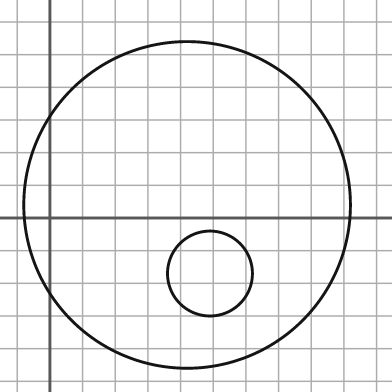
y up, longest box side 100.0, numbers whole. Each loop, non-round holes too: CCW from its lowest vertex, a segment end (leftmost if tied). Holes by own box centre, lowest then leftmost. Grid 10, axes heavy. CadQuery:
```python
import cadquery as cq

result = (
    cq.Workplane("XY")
    .moveTo(42.0, 4.0)
    .circle(50.0)
    .moveTo(49.0, -17.0)
    .circle(13.0)
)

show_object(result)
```